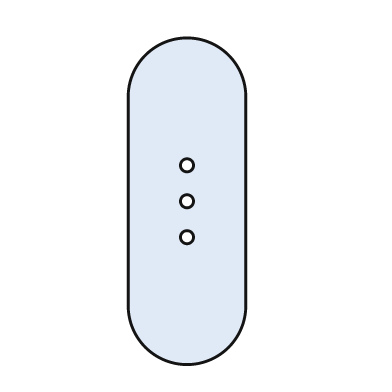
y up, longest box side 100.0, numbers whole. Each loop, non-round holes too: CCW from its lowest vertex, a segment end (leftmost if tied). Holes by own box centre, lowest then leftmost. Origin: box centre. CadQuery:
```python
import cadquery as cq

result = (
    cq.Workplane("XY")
    .moveTo(-18.0, -32.0)
    .threePointArc((0.0, -50.0), (18.0, -32.0))
    .lineTo(18.0, 32.0)
    .threePointArc((0.0, 50.0), (-18.0, 32.0))
    .close()
    .moveTo(0.0, -11.0)
    .circle(2.0)
    .moveTo(0.0, 0.0)
    .circle(2.0)
    .moveTo(0.0, 11.0)
    .circle(2.0)
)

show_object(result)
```